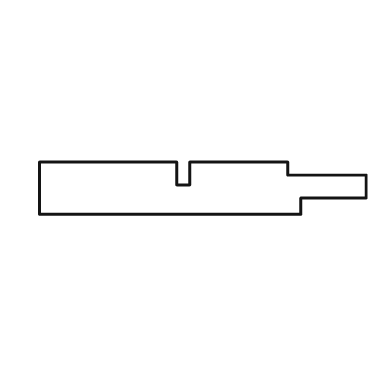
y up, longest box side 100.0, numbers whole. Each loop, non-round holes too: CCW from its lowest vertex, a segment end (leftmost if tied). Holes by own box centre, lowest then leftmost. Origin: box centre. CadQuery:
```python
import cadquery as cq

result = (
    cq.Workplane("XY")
    .moveTo(-50.0, -8.0)
    .lineTo(30.0, -8.0)
    .lineTo(30.0, -3.0)
    .lineTo(50.0, -3.0)
    .lineTo(50.0, 4.0)
    .lineTo(26.0, 4.0)
    .lineTo(26.0, 8.0)
    .lineTo(-4.0, 8.0)
    .lineTo(-4.0, 1.0)
    .lineTo(-8.0, 1.0)
    .lineTo(-8.0, 8.0)
    .lineTo(-50.0, 8.0)
    .close()
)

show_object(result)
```